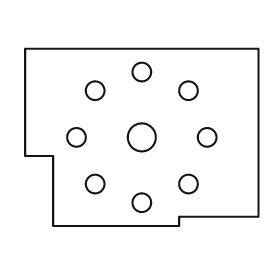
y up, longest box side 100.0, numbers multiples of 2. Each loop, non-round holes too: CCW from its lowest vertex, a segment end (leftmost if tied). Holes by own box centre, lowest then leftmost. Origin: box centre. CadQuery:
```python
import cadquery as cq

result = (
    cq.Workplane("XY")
    .moveTo(-38.0, -38.0)
    .lineTo(16.0, -38.0)
    .lineTo(16.0, -34.0)
    .lineTo(50.0, -34.0)
    .lineTo(50.0, 38.0)
    .lineTo(-50.0, 38.0)
    .lineTo(-50.0, -8.0)
    .lineTo(-38.0, -8.0)
    .close()
    .moveTo(0.0, -28.0)
    .circle(4.0)
    .moveTo(-20.0, -20.0)
    .circle(4.0)
    .moveTo(20.0, -20.0)
    .circle(4.0)
    .moveTo(-28.0, 0.0)
    .circle(4.0)
    .moveTo(0.0, 0.0)
    .circle(6.0)
    .moveTo(28.0, 0.0)
    .circle(4.0)
    .moveTo(-20.0, 20.0)
    .circle(4.0)
    .moveTo(20.0, 20.0)
    .circle(4.0)
    .moveTo(0.0, 28.0)
    .circle(4.0)
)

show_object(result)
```